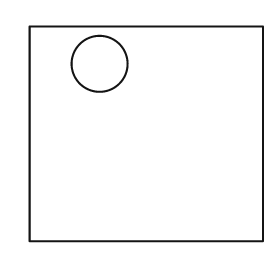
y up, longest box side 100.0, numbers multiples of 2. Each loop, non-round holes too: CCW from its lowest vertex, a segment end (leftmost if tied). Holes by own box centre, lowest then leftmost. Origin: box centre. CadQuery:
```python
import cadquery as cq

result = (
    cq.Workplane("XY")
    .moveTo(-50.0, -46.0)
    .lineTo(50.0, -46.0)
    .lineTo(50.0, 46.0)
    .lineTo(-50.0, 46.0)
    .close()
    .moveTo(-20.0, 30.0)
    .circle(12.0)
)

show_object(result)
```